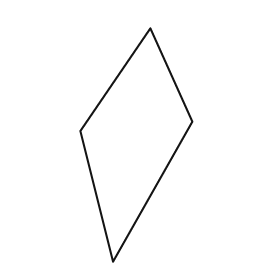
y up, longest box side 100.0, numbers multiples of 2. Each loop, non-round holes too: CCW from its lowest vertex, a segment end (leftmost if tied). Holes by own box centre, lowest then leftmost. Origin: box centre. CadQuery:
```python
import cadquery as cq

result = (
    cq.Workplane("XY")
    .moveTo(-10.0, -50.0)
    .lineTo(24.0, 10.0)
    .lineTo(6.0, 50.0)
    .lineTo(-24.0, 6.0)
    .close()
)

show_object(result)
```